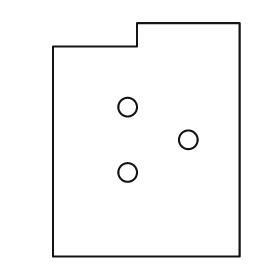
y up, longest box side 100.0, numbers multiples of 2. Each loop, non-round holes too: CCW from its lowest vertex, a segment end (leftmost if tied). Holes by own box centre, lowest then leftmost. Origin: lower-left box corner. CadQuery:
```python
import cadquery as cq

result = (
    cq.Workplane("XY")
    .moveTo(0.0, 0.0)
    .lineTo(80.0, 0.0)
    .lineTo(80.0, 100.0)
    .lineTo(36.0, 100.0)
    .lineTo(36.0, 90.0)
    .lineTo(0.0, 90.0)
    .close()
    .moveTo(32.0, 36.0)
    .circle(4.0)
    .moveTo(58.0, 50.0)
    .circle(4.0)
    .moveTo(32.0, 64.0)
    .circle(4.0)
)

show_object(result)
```